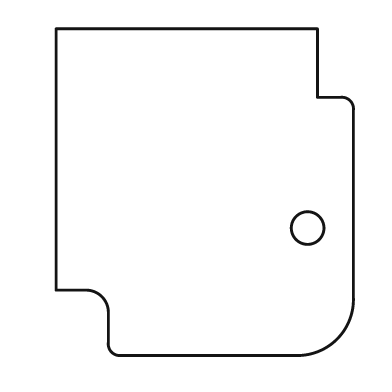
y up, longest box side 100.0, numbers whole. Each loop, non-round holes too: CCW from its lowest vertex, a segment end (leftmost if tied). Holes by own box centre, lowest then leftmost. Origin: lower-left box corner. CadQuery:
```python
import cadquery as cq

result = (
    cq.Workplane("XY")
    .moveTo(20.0, 0.0)
    .lineTo(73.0, 0.0)
    .threePointArc((86.0, 5.0), (91.0, 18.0))
    .lineTo(91.0, 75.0)
    .threePointArc((90.0, 78.0), (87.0, 79.0))
    .lineTo(80.0, 79.0)
    .lineTo(80.0, 100.0)
    .lineTo(0.0, 100.0)
    .lineTo(0.0, 20.0)
    .lineTo(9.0, 20.0)
    .threePointArc((14.0, 18.0), (16.0, 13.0))
    .lineTo(16.0, 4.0)
    .threePointArc((17.0, 1.0), (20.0, 0.0))
    .close()
    .moveTo(77.0, 39.0)
    .circle(5.0)
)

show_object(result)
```